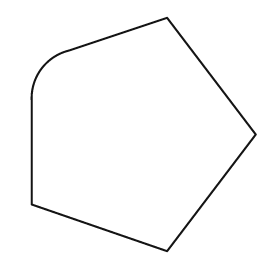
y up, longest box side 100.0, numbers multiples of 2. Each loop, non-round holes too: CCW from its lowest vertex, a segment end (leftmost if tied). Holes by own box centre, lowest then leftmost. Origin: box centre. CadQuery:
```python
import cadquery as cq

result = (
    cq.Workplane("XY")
    .moveTo(10.0, -50.0)
    .lineTo(48.0, 0.0)
    .lineTo(10.0, 50.0)
    .lineTo(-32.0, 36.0)
    .threePointArc((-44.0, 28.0), (-48.0, 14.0))
    .lineTo(-48.0, -30.0)
    .close()
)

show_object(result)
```